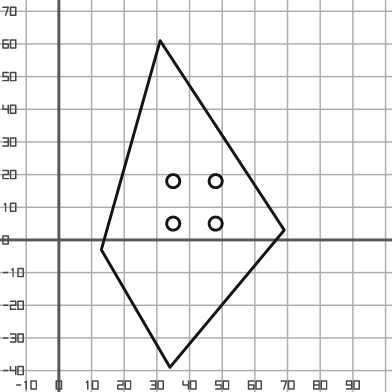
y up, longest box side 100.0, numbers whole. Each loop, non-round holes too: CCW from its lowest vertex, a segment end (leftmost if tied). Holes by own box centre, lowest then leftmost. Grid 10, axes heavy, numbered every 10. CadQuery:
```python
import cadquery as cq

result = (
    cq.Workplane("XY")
    .moveTo(34.0, -39.0)
    .lineTo(69.0, 3.0)
    .lineTo(31.0, 61.0)
    .lineTo(13.0, -3.0)
    .close()
    .moveTo(35.0, 5.0)
    .circle(2.0)
    .moveTo(48.0, 5.0)
    .circle(2.0)
    .moveTo(35.0, 18.0)
    .circle(2.0)
    .moveTo(48.0, 18.0)
    .circle(2.0)
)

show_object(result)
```